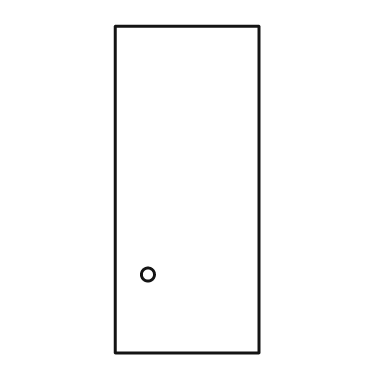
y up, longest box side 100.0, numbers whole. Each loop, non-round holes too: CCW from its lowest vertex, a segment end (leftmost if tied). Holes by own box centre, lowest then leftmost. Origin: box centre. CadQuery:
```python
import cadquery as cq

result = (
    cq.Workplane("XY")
    .moveTo(-22.0, -50.0)
    .lineTo(22.0, -50.0)
    .lineTo(22.0, 50.0)
    .lineTo(-22.0, 50.0)
    .close()
    .moveTo(-12.0, -26.0)
    .circle(2.0)
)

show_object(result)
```